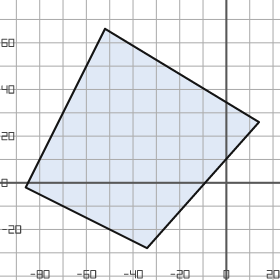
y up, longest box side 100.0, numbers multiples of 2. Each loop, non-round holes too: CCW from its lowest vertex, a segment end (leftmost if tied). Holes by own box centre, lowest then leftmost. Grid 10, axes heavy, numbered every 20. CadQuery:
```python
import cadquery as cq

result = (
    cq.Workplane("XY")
    .moveTo(-34.0, -28.0)
    .lineTo(14.0, 26.0)
    .lineTo(-52.0, 66.0)
    .lineTo(-86.0, -2.0)
    .close()
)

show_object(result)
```